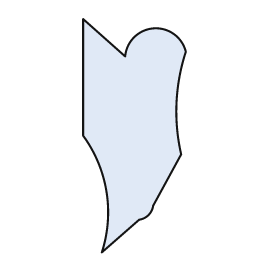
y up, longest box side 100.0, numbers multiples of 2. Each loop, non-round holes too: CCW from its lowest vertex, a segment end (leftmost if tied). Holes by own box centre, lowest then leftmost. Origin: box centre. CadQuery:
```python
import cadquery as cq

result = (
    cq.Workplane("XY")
    .moveTo(-14.0, -50.0)
    .lineTo(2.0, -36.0)
    .threePointArc((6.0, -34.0), (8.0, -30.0))
    .lineTo(20.0, -8.0)
    .threePointArc((18.0, 14.0), (22.0, 36.0))
    .threePointArc((8.0, 46.0), (-4.0, 34.0))
    .lineTo(-22.0, 50.0)
    .lineTo(-22.0, 0.0)
    .threePointArc((-12.0, -24.0), (-14.0, -50.0))
    .close()
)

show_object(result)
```